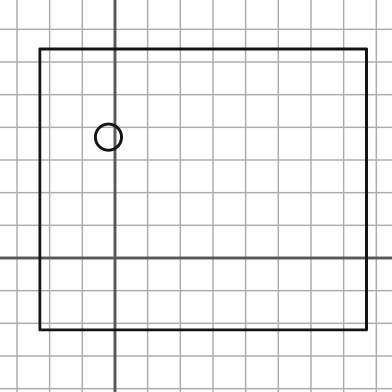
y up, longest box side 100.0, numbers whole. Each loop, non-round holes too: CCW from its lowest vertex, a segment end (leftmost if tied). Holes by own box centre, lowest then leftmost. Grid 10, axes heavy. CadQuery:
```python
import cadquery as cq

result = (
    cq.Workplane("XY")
    .moveTo(-23.0, -22.0)
    .lineTo(77.0, -22.0)
    .lineTo(77.0, 64.0)
    .lineTo(-23.0, 64.0)
    .close()
    .moveTo(-2.0, 37.0)
    .circle(4.0)
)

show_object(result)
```